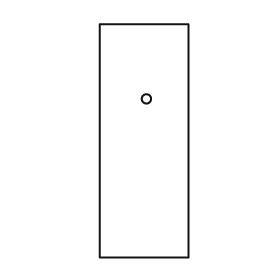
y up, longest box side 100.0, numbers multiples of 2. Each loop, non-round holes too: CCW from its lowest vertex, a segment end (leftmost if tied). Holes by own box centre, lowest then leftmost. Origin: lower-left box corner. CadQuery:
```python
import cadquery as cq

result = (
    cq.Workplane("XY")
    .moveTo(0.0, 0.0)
    .lineTo(38.0, 0.0)
    .lineTo(38.0, 100.0)
    .lineTo(0.0, 100.0)
    .close()
    .moveTo(20.0, 68.0)
    .circle(2.0)
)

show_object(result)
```